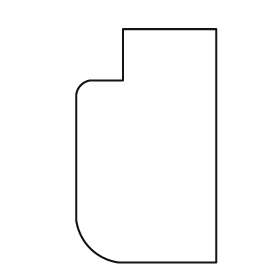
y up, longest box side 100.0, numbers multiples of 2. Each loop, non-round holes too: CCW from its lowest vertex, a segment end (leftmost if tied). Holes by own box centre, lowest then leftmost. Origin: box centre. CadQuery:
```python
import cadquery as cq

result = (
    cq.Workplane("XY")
    .moveTo(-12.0, -50.0)
    .lineTo(30.0, -50.0)
    .lineTo(30.0, 50.0)
    .lineTo(-10.0, 50.0)
    .lineTo(-10.0, 28.0)
    .lineTo(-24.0, 28.0)
    .threePointArc((-28.0, 26.0), (-30.0, 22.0))
    .lineTo(-30.0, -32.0)
    .threePointArc((-24.0, -44.0), (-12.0, -50.0))
    .close()
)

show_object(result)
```